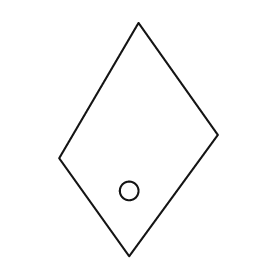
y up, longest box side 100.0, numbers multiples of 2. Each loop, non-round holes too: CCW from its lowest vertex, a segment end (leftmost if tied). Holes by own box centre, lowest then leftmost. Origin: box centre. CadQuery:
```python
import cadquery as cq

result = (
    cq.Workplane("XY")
    .moveTo(-4.0, -50.0)
    .lineTo(34.0, 2.0)
    .lineTo(0.0, 50.0)
    .lineTo(-34.0, -8.0)
    .close()
    .moveTo(-4.0, -22.0)
    .circle(4.0)
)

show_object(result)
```